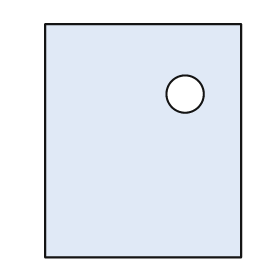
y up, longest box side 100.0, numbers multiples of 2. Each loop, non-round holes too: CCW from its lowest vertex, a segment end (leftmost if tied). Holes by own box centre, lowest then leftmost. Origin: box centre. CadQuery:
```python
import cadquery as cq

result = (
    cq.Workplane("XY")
    .moveTo(-42.0, -50.0)
    .lineTo(42.0, -50.0)
    .lineTo(42.0, 50.0)
    .lineTo(-42.0, 50.0)
    .close()
    .moveTo(18.0, 20.0)
    .circle(8.0)
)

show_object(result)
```